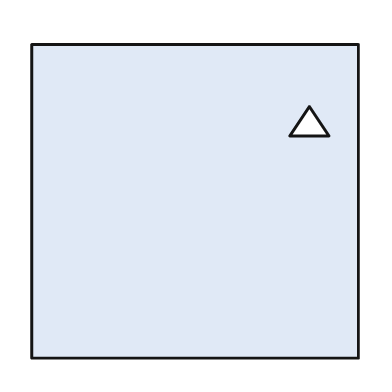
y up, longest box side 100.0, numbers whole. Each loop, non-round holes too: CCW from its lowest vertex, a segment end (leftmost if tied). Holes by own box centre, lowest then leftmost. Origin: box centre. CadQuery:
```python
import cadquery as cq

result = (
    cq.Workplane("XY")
    .moveTo(-50.0, -48.0)
    .lineTo(50.0, -48.0)
    .lineTo(50.0, 48.0)
    .lineTo(-50.0, 48.0)
    .close()
    .moveTo(29.0, 20.0)
    .lineTo(41.0, 20.0)
    .lineTo(35.0, 29.0)
    .close()
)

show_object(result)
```